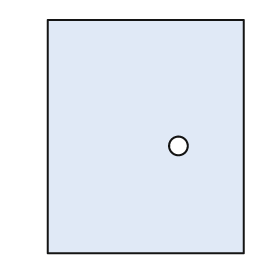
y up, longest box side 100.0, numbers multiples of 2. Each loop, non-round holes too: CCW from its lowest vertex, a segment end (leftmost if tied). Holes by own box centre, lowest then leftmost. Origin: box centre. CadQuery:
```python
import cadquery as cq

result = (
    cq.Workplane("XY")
    .moveTo(-42.0, -50.0)
    .lineTo(42.0, -50.0)
    .lineTo(42.0, 50.0)
    .lineTo(-42.0, 50.0)
    .close()
    .moveTo(14.0, -4.0)
    .circle(4.0)
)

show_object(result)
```